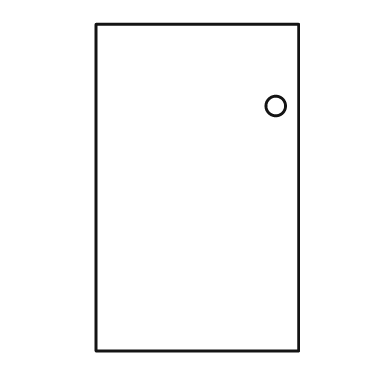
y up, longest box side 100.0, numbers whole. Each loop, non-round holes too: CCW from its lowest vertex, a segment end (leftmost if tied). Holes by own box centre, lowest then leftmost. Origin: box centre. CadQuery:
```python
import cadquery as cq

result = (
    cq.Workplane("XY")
    .moveTo(-31.0, -50.0)
    .lineTo(31.0, -50.0)
    .lineTo(31.0, 50.0)
    .lineTo(-31.0, 50.0)
    .close()
    .moveTo(24.0, 25.0)
    .circle(3.0)
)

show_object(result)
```